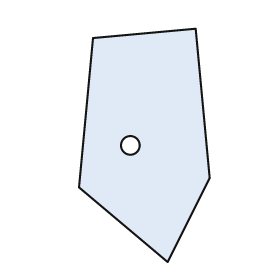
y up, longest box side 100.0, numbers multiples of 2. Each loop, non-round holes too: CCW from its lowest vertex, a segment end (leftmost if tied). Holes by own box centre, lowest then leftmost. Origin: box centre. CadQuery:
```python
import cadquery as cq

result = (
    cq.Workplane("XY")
    .moveTo(10.0, -50.0)
    .lineTo(28.0, -14.0)
    .lineTo(22.0, 50.0)
    .lineTo(-22.0, 46.0)
    .lineTo(-28.0, -18.0)
    .close()
    .moveTo(-6.0, 0.0)
    .circle(4.0)
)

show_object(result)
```